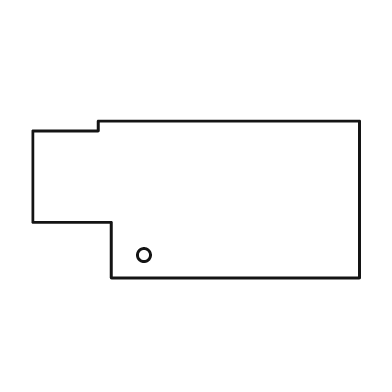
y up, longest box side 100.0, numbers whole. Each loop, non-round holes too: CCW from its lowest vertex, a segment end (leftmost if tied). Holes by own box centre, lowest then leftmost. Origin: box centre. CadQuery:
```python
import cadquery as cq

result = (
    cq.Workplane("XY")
    .moveTo(-26.0, -24.0)
    .lineTo(50.0, -24.0)
    .lineTo(50.0, 24.0)
    .lineTo(-30.0, 24.0)
    .lineTo(-30.0, 21.0)
    .lineTo(-50.0, 21.0)
    .lineTo(-50.0, -7.0)
    .lineTo(-26.0, -7.0)
    .close()
    .moveTo(-16.0, -17.0)
    .circle(2.0)
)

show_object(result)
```